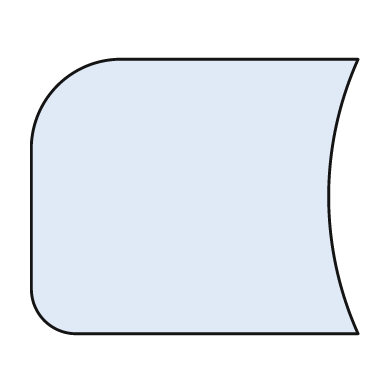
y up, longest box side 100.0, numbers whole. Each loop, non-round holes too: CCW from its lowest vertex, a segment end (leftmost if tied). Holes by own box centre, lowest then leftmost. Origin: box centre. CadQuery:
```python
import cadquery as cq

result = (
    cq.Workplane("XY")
    .moveTo(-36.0, -42.0)
    .lineTo(50.0, -42.0)
    .threePointArc((41.0, 0.0), (50.0, 42.0))
    .lineTo(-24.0, 42.0)
    .threePointArc((-42.0, 34.0), (-50.0, 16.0))
    .lineTo(-50.0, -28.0)
    .threePointArc((-46.0, -38.0), (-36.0, -42.0))
    .close()
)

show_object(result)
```